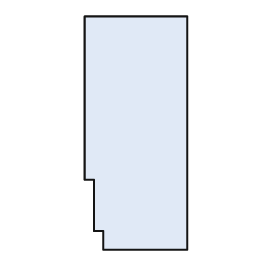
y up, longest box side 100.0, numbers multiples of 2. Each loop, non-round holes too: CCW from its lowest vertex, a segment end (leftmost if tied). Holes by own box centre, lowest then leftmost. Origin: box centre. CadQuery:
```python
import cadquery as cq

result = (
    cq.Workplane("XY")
    .moveTo(-14.0, -50.0)
    .lineTo(22.0, -50.0)
    .lineTo(22.0, 50.0)
    .lineTo(-22.0, 50.0)
    .lineTo(-22.0, -20.0)
    .lineTo(-18.0, -20.0)
    .lineTo(-18.0, -42.0)
    .lineTo(-14.0, -42.0)
    .close()
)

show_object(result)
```